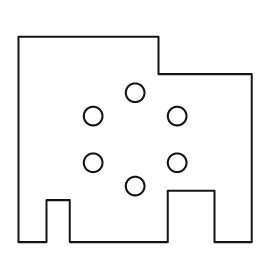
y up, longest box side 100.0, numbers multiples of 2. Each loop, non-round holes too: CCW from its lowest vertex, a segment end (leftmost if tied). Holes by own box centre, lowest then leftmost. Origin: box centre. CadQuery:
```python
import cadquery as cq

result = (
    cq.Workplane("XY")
    .moveTo(-50.0, -44.0)
    .lineTo(-38.0, -44.0)
    .lineTo(-38.0, -26.0)
    .lineTo(-28.0, -26.0)
    .lineTo(-28.0, -44.0)
    .lineTo(14.0, -44.0)
    .lineTo(14.0, -22.0)
    .lineTo(34.0, -22.0)
    .lineTo(34.0, -44.0)
    .lineTo(50.0, -44.0)
    .lineTo(50.0, 28.0)
    .lineTo(10.0, 28.0)
    .lineTo(10.0, 44.0)
    .lineTo(-50.0, 44.0)
    .close()
    .moveTo(0.0, -20.0)
    .circle(4.0)
    .moveTo(-18.0, -10.0)
    .circle(4.0)
    .moveTo(18.0, -10.0)
    .circle(4.0)
    .moveTo(-18.0, 10.0)
    .circle(4.0)
    .moveTo(18.0, 10.0)
    .circle(4.0)
    .moveTo(0.0, 20.0)
    .circle(4.0)
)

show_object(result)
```